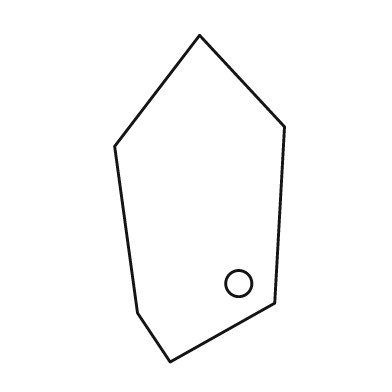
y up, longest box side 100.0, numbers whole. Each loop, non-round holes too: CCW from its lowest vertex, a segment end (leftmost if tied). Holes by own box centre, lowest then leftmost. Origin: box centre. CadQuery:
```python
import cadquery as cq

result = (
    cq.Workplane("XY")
    .moveTo(-9.0, -50.0)
    .lineTo(23.0, -32.0)
    .lineTo(26.0, 22.0)
    .lineTo(0.0, 50.0)
    .lineTo(-26.0, 16.0)
    .lineTo(-19.0, -35.0)
    .close()
    .moveTo(12.0, -26.0)
    .circle(4.0)
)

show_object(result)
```